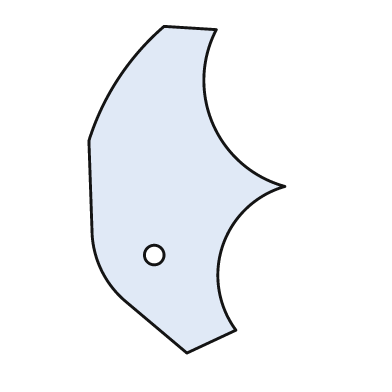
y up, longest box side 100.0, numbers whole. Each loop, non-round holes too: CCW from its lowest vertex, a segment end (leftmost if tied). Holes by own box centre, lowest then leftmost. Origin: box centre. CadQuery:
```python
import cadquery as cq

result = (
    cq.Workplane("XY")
    .moveTo(0.0, -50.0)
    .lineTo(15.0, -43.0)
    .threePointArc((11.0, -17.0), (30.0, 1.0))
    .threePointArc((8.0, 20.0), (9.0, 49.0))
    .lineTo(-7.0, 50.0)
    .threePointArc((-21.0, 34.0), (-30.0, 15.0))
    .lineTo(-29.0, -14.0)
    .threePointArc((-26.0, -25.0), (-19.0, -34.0))
    .close()
    .moveTo(-10.0, -20.0)
    .circle(3.0)
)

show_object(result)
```